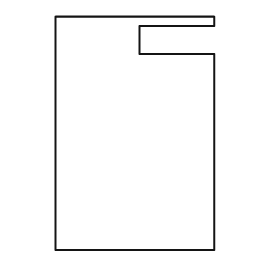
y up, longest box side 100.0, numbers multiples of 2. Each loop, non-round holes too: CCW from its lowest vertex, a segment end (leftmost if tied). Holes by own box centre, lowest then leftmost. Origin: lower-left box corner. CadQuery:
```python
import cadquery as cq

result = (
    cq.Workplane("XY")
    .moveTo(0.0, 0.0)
    .lineTo(68.0, 0.0)
    .lineTo(68.0, 84.0)
    .lineTo(36.0, 84.0)
    .lineTo(36.0, 96.0)
    .lineTo(68.0, 96.0)
    .lineTo(68.0, 100.0)
    .lineTo(0.0, 100.0)
    .close()
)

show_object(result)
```